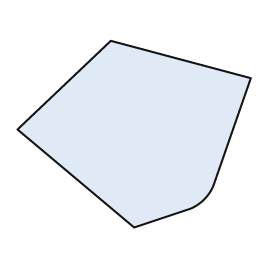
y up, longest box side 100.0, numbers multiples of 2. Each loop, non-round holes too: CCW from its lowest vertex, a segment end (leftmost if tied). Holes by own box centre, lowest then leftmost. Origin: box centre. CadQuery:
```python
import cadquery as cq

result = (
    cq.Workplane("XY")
    .moveTo(0.0, -40.0)
    .lineTo(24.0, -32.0)
    .threePointArc((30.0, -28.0), (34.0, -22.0))
    .lineTo(50.0, 24.0)
    .lineTo(-10.0, 40.0)
    .lineTo(-50.0, 2.0)
    .close()
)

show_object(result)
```